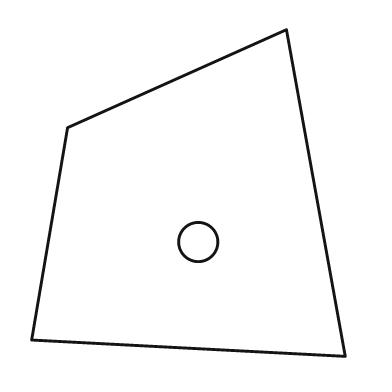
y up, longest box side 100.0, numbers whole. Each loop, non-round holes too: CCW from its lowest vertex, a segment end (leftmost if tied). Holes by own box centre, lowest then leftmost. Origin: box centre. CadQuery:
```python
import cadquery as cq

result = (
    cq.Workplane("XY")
    .moveTo(48.0, -50.0)
    .lineTo(30.0, 50.0)
    .lineTo(-37.0, 20.0)
    .lineTo(-48.0, -45.0)
    .close()
    .moveTo(3.0, -15.0)
    .circle(6.0)
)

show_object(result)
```